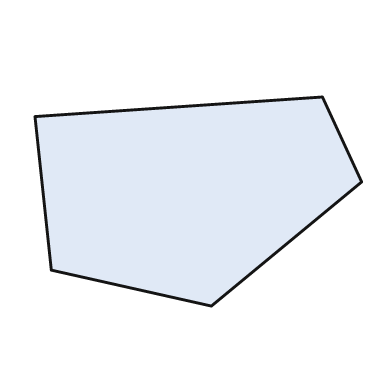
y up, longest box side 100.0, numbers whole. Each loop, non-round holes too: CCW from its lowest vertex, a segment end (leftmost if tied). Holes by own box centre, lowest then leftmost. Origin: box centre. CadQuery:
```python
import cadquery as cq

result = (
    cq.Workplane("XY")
    .moveTo(4.0, -32.0)
    .lineTo(50.0, 6.0)
    .lineTo(38.0, 32.0)
    .lineTo(-50.0, 26.0)
    .lineTo(-45.0, -21.0)
    .close()
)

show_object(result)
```